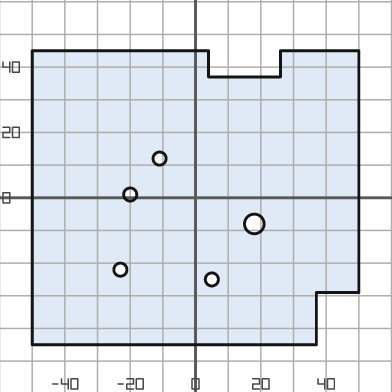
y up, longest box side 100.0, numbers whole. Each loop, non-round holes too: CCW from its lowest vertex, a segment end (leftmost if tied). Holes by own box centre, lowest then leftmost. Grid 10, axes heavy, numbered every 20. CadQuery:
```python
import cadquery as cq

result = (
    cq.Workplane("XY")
    .moveTo(-50.0, -45.0)
    .lineTo(37.0, -45.0)
    .lineTo(37.0, -29.0)
    .lineTo(50.0, -29.0)
    .lineTo(50.0, 45.0)
    .lineTo(26.0, 45.0)
    .lineTo(26.0, 37.0)
    .lineTo(4.0, 37.0)
    .lineTo(4.0, 45.0)
    .lineTo(-50.0, 45.0)
    .close()
    .moveTo(5.0, -25.0)
    .circle(2.0)
    .moveTo(-23.0, -22.0)
    .circle(2.0)
    .moveTo(18.0, -8.0)
    .circle(3.0)
    .moveTo(-20.0, 1.0)
    .circle(2.0)
    .moveTo(-11.0, 12.0)
    .circle(2.0)
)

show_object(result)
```